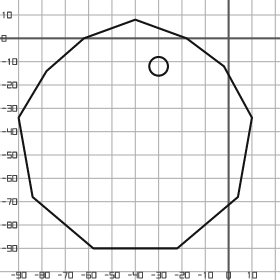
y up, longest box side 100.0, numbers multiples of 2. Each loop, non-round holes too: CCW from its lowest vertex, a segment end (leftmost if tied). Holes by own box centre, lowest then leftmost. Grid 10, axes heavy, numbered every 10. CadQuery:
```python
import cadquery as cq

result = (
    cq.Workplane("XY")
    .moveTo(-58.0, -90.0)
    .lineTo(-22.0, -90.0)
    .lineTo(4.0, -68.0)
    .lineTo(10.0, -34.0)
    .lineTo(-2.0, -12.0)
    .lineTo(-18.0, 0.0)
    .lineTo(-40.0, 8.0)
    .lineTo(-62.0, 0.0)
    .lineTo(-78.0, -14.0)
    .lineTo(-90.0, -34.0)
    .lineTo(-84.0, -68.0)
    .close()
    .moveTo(-30.0, -12.0)
    .circle(4.0)
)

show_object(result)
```